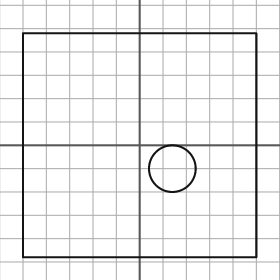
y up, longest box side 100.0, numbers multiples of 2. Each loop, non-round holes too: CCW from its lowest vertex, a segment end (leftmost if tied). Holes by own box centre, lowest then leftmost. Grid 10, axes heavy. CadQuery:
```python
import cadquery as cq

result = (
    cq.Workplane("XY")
    .moveTo(-50.0, -48.0)
    .lineTo(50.0, -48.0)
    .lineTo(50.0, 48.0)
    .lineTo(-50.0, 48.0)
    .close()
    .moveTo(14.0, -10.0)
    .circle(10.0)
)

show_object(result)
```